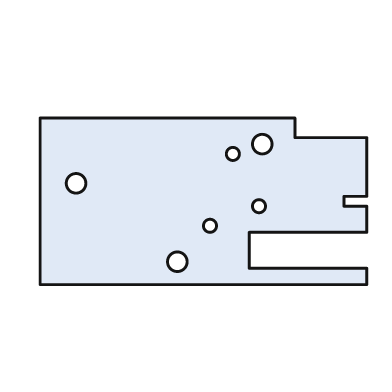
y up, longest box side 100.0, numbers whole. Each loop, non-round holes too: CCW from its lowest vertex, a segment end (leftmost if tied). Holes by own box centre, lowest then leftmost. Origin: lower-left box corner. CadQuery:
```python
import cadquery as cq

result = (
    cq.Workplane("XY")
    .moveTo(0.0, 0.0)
    .lineTo(100.0, 0.0)
    .lineTo(100.0, 5.0)
    .lineTo(64.0, 5.0)
    .lineTo(64.0, 16.0)
    .lineTo(100.0, 16.0)
    .lineTo(100.0, 24.0)
    .lineTo(93.0, 24.0)
    .lineTo(93.0, 27.0)
    .lineTo(100.0, 27.0)
    .lineTo(100.0, 45.0)
    .lineTo(78.0, 45.0)
    .lineTo(78.0, 51.0)
    .lineTo(0.0, 51.0)
    .close()
    .moveTo(42.0, 7.0)
    .circle(3.0)
    .moveTo(52.0, 18.0)
    .circle(2.0)
    .moveTo(67.0, 24.0)
    .circle(2.0)
    .moveTo(11.0, 31.0)
    .circle(3.0)
    .moveTo(59.0, 40.0)
    .circle(2.0)
    .moveTo(68.0, 43.0)
    .circle(3.0)
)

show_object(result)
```